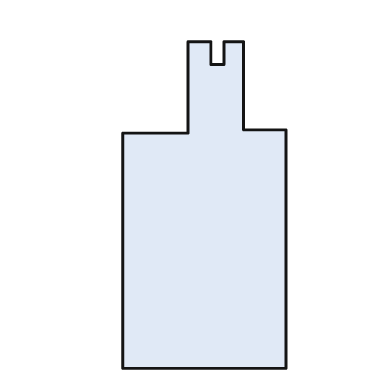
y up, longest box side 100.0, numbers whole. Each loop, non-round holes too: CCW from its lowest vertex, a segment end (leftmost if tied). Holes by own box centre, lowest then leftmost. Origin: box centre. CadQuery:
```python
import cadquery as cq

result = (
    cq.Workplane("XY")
    .moveTo(-25.0, -50.0)
    .lineTo(25.0, -50.0)
    .lineTo(25.0, 23.0)
    .lineTo(12.0, 23.0)
    .lineTo(12.0, 50.0)
    .lineTo(6.0, 50.0)
    .lineTo(6.0, 43.0)
    .lineTo(2.0, 43.0)
    .lineTo(2.0, 50.0)
    .lineTo(-5.0, 50.0)
    .lineTo(-5.0, 22.0)
    .lineTo(-25.0, 22.0)
    .close()
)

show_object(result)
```